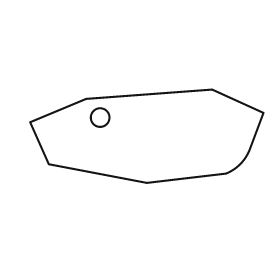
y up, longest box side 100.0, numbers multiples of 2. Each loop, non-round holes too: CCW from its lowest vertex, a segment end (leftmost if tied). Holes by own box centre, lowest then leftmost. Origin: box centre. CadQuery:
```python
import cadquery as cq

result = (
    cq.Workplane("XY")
    .moveTo(0.0, -20.0)
    .lineTo(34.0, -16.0)
    .threePointArc((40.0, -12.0), (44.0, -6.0))
    .lineTo(50.0, 10.0)
    .lineTo(28.0, 20.0)
    .lineTo(-26.0, 16.0)
    .lineTo(-50.0, 6.0)
    .lineTo(-42.0, -12.0)
    .close()
    .moveTo(-20.0, 8.0)
    .circle(4.0)
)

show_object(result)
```